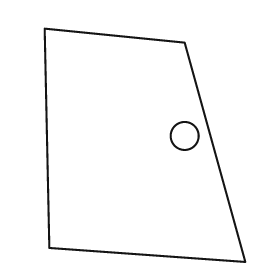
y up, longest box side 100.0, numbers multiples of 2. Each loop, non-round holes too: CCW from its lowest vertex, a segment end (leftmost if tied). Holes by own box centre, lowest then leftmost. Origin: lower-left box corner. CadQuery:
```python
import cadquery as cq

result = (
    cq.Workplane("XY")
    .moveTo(86.0, 0.0)
    .lineTo(60.0, 94.0)
    .lineTo(0.0, 100.0)
    .lineTo(2.0, 6.0)
    .close()
    .moveTo(60.0, 54.0)
    .circle(6.0)
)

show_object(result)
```